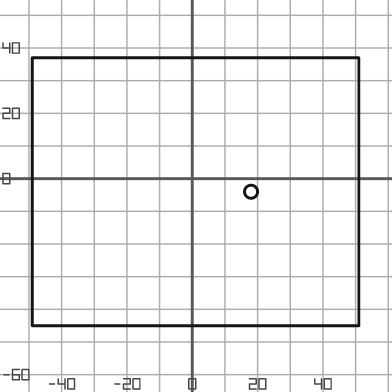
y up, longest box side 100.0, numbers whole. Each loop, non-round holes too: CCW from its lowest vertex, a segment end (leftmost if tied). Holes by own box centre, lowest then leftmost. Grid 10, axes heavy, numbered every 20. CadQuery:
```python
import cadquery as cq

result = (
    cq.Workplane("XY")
    .moveTo(-49.0, -45.0)
    .lineTo(51.0, -45.0)
    .lineTo(51.0, 37.0)
    .lineTo(-49.0, 37.0)
    .close()
    .moveTo(18.0, -4.0)
    .circle(2.0)
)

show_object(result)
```